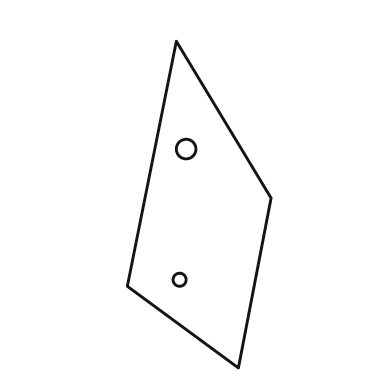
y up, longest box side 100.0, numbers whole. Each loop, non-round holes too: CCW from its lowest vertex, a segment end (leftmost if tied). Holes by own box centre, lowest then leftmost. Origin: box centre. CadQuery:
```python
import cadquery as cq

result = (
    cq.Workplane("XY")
    .moveTo(12.0, -50.0)
    .lineTo(22.0, 2.0)
    .lineTo(-7.0, 50.0)
    .lineTo(-22.0, -25.0)
    .close()
    .moveTo(-6.0, -23.0)
    .circle(2.0)
    .moveTo(-4.0, 17.0)
    .circle(3.0)
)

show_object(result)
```